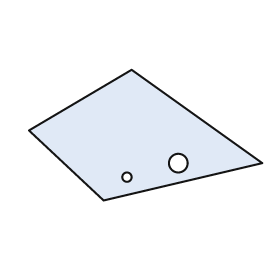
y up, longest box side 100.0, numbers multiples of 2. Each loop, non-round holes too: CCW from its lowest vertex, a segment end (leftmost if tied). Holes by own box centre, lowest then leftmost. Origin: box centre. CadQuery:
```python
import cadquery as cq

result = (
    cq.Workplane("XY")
    .moveTo(-18.0, -28.0)
    .lineTo(50.0, -12.0)
    .lineTo(-6.0, 28.0)
    .lineTo(-50.0, 2.0)
    .close()
    .moveTo(-8.0, -18.0)
    .circle(2.0)
    .moveTo(14.0, -12.0)
    .circle(4.0)
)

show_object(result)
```